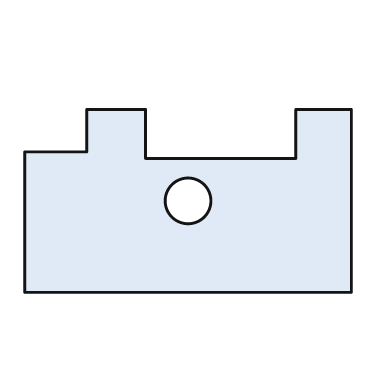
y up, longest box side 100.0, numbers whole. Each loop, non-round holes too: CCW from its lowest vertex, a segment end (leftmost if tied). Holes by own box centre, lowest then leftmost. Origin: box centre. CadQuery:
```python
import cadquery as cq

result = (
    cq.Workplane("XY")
    .moveTo(-50.0, -28.0)
    .lineTo(50.0, -28.0)
    .lineTo(50.0, 28.0)
    .lineTo(33.0, 28.0)
    .lineTo(33.0, 13.0)
    .lineTo(-13.0, 13.0)
    .lineTo(-13.0, 28.0)
    .lineTo(-31.0, 28.0)
    .lineTo(-31.0, 15.0)
    .lineTo(-50.0, 15.0)
    .close()
    .moveTo(0.0, 0.0)
    .circle(7.0)
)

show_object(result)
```